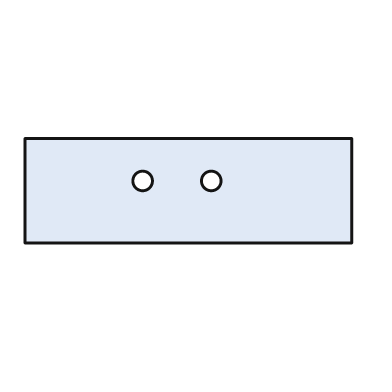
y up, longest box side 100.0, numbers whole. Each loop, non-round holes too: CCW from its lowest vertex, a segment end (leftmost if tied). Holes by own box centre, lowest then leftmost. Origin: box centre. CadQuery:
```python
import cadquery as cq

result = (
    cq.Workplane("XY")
    .moveTo(-50.0, -16.0)
    .lineTo(50.0, -16.0)
    .lineTo(50.0, 16.0)
    .lineTo(-50.0, 16.0)
    .close()
    .moveTo(-14.0, 3.0)
    .circle(3.0)
    .moveTo(7.0, 3.0)
    .circle(3.0)
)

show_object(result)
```